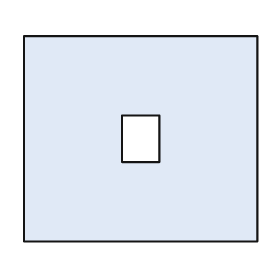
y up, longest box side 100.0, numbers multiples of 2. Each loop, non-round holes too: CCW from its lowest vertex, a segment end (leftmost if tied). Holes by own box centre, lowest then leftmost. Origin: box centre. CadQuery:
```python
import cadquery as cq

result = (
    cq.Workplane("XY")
    .moveTo(-50.0, -44.0)
    .lineTo(50.0, -44.0)
    .lineTo(50.0, 44.0)
    .lineTo(-50.0, 44.0)
    .close()
    .moveTo(-8.0, -10.0)
    .lineTo(8.0, -10.0)
    .lineTo(8.0, 10.0)
    .lineTo(-8.0, 10.0)
    .close()
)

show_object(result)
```